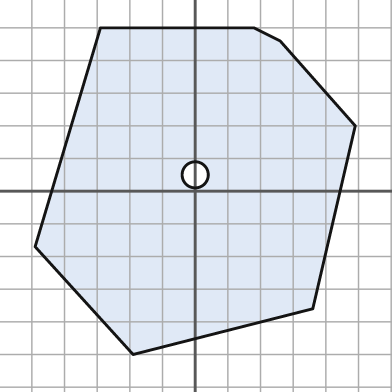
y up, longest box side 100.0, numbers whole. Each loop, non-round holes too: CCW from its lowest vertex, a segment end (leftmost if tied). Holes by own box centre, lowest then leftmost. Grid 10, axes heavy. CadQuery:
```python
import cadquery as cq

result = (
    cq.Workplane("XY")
    .moveTo(-19.0, -50.0)
    .lineTo(36.0, -36.0)
    .lineTo(49.0, 20.0)
    .lineTo(26.0, 46.0)
    .lineTo(18.0, 50.0)
    .lineTo(-29.0, 50.0)
    .lineTo(-49.0, -17.0)
    .close()
    .moveTo(0.0, 5.0)
    .circle(4.0)
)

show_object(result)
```